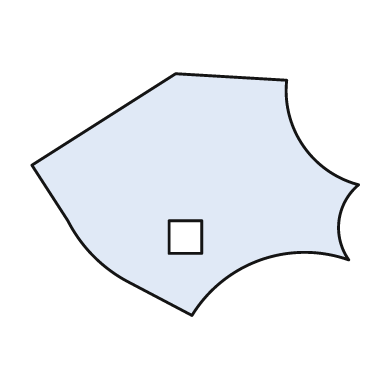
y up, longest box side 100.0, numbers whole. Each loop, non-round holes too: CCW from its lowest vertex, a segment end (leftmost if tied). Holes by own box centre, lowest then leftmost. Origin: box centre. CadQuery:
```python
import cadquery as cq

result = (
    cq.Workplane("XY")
    .moveTo(-1.0, -37.0)
    .threePointArc((20.0, -20.0), (47.0, -20.0))
    .threePointArc((44.0, -8.0), (50.0, 3.0))
    .threePointArc((33.0, 15.0), (28.0, 35.0))
    .lineTo(-6.0, 37.0)
    .lineTo(-50.0, 9.0)
    .lineTo(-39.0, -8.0)
    .threePointArc((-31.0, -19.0), (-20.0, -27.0))
    .close()
    .moveTo(-8.0, -18.0)
    .lineTo(2.0, -18.0)
    .lineTo(2.0, -8.0)
    .lineTo(-8.0, -8.0)
    .close()
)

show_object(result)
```